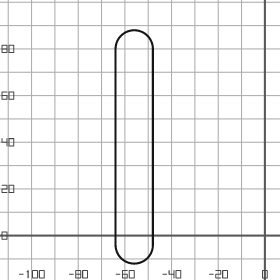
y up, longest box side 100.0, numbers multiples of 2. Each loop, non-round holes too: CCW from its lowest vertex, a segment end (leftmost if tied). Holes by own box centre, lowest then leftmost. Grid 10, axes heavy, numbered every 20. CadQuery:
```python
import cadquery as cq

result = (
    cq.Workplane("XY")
    .moveTo(-64.0, -4.0)
    .threePointArc((-56.0, -12.0), (-48.0, -4.0))
    .lineTo(-48.0, 80.0)
    .threePointArc((-56.0, 88.0), (-64.0, 80.0))
    .close()
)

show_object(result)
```